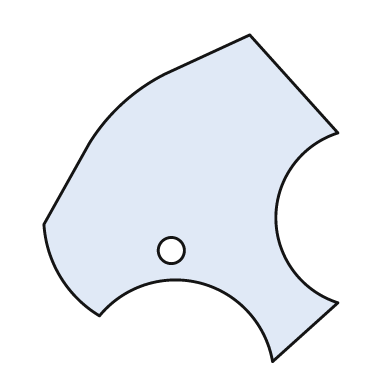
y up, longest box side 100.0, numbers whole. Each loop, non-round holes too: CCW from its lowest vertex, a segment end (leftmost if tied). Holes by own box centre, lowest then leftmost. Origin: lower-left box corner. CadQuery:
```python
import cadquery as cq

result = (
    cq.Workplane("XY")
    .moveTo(70.0, 0.0)
    .lineTo(90.0, 18.0)
    .threePointArc((71.0, 44.0), (90.0, 70.0))
    .lineTo(63.0, 100.0)
    .lineTo(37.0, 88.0)
    .threePointArc((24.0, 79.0), (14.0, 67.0))
    .lineTo(0.0, 42.0)
    .threePointArc((5.0, 26.0), (17.0, 14.0))
    .threePointArc((48.0, 24.0), (70.0, 0.0))
    .close()
    .moveTo(39.0, 34.0)
    .circle(4.0)
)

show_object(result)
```